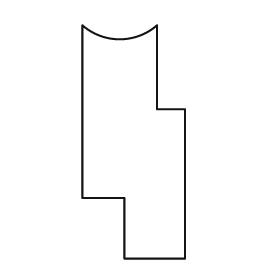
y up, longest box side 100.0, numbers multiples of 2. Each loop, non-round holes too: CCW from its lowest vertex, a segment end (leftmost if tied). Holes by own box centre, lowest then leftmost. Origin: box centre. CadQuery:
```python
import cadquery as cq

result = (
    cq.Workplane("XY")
    .moveTo(-4.0, -50.0)
    .lineTo(22.0, -50.0)
    .lineTo(22.0, 14.0)
    .lineTo(10.0, 14.0)
    .lineTo(10.0, 50.0)
    .threePointArc((-6.0, 44.0), (-22.0, 50.0))
    .lineTo(-22.0, -24.0)
    .lineTo(-4.0, -24.0)
    .close()
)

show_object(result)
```